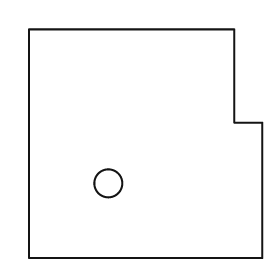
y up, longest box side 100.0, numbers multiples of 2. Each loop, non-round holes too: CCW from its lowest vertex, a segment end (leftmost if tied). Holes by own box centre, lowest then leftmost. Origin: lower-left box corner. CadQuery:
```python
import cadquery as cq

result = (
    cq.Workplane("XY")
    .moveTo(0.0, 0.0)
    .lineTo(100.0, 0.0)
    .lineTo(100.0, 58.0)
    .lineTo(88.0, 58.0)
    .lineTo(88.0, 98.0)
    .lineTo(0.0, 98.0)
    .close()
    .moveTo(34.0, 32.0)
    .circle(6.0)
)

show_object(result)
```